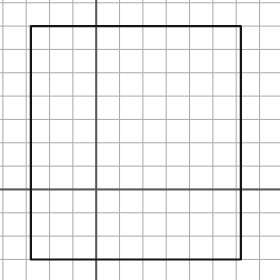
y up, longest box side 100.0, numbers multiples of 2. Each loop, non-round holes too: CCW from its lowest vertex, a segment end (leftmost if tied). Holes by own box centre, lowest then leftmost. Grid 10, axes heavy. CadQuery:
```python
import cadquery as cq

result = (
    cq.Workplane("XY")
    .moveTo(-28.0, -30.0)
    .lineTo(62.0, -30.0)
    .lineTo(62.0, 70.0)
    .lineTo(-28.0, 70.0)
    .close()
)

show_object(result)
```